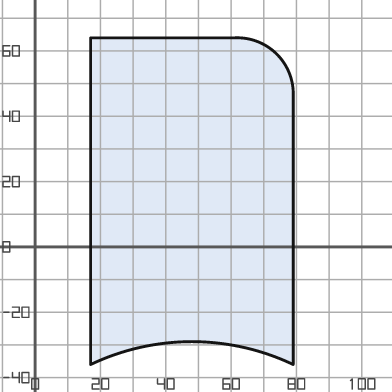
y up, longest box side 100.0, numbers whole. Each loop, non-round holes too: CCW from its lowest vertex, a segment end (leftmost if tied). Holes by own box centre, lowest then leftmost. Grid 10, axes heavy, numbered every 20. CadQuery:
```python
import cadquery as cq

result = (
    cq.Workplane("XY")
    .moveTo(17.0, -36.0)
    .threePointArc((48.0, -29.0), (79.0, -36.0))
    .lineTo(79.0, 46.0)
    .threePointArc((74.0, 59.0), (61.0, 64.0))
    .lineTo(17.0, 64.0)
    .close()
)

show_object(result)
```